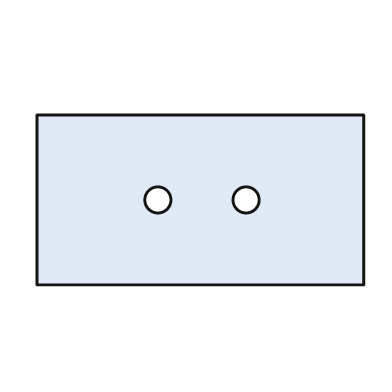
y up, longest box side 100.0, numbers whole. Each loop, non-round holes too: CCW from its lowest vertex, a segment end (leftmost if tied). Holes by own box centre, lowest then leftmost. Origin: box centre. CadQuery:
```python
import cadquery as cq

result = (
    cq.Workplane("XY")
    .moveTo(-50.0, -26.0)
    .lineTo(50.0, -26.0)
    .lineTo(50.0, 26.0)
    .lineTo(-50.0, 26.0)
    .close()
    .moveTo(-13.0, 0.0)
    .circle(4.0)
    .moveTo(14.0, 0.0)
    .circle(4.0)
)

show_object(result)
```